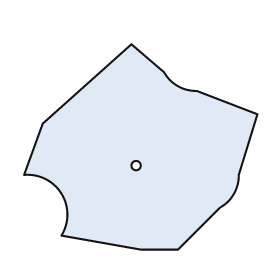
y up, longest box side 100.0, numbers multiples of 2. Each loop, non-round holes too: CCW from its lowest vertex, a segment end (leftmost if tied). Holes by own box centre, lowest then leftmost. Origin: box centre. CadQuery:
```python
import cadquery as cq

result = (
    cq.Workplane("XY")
    .moveTo(0.0, -44.0)
    .lineTo(16.0, -44.0)
    .lineTo(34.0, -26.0)
    .threePointArc((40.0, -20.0), (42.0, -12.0))
    .lineTo(50.0, 14.0)
    .lineTo(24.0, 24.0)
    .threePointArc((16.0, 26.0), (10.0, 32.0))
    .lineTo(-4.0, 44.0)
    .lineTo(-42.0, 10.0)
    .lineTo(-50.0, -12.0)
    .threePointArc((-34.0, -20.0), (-34.0, -38.0))
    .close()
    .moveTo(-2.0, -8.0)
    .circle(2.0)
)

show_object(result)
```